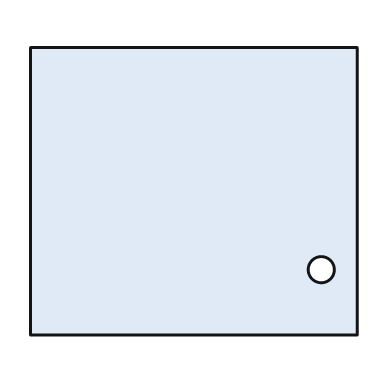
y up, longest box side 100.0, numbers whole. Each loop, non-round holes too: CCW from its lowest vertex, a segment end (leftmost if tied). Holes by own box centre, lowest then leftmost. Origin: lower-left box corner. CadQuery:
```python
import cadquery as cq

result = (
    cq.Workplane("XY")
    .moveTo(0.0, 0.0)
    .lineTo(100.0, 0.0)
    .lineTo(100.0, 88.0)
    .lineTo(0.0, 88.0)
    .close()
    .moveTo(89.0, 20.0)
    .circle(4.0)
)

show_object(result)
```